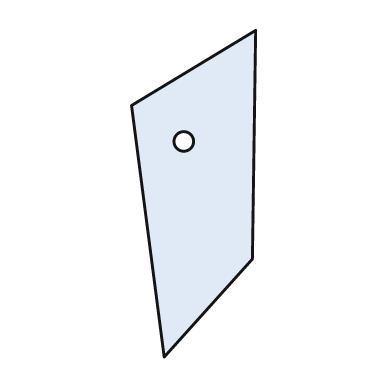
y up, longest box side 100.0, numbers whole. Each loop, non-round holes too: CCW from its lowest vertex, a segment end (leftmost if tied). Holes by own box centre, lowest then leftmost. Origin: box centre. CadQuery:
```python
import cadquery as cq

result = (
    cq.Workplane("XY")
    .moveTo(-9.0, -50.0)
    .lineTo(18.0, -20.0)
    .lineTo(19.0, 50.0)
    .lineTo(-19.0, 27.0)
    .close()
    .moveTo(-3.0, 16.0)
    .circle(3.0)
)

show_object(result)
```